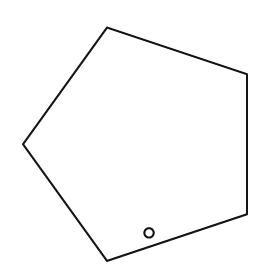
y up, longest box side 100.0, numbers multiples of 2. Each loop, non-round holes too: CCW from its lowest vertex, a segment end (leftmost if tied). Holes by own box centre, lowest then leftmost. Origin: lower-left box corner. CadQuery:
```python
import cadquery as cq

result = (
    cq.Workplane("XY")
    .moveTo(36.0, 0.0)
    .lineTo(96.0, 20.0)
    .lineTo(96.0, 80.0)
    .lineTo(36.0, 100.0)
    .lineTo(0.0, 50.0)
    .close()
    .moveTo(54.0, 12.0)
    .circle(2.0)
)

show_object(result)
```